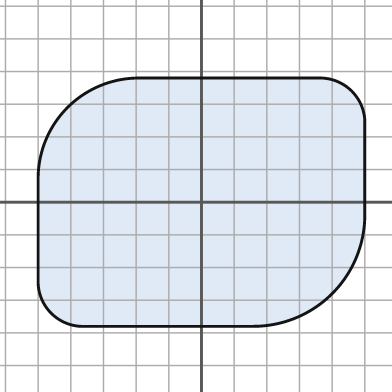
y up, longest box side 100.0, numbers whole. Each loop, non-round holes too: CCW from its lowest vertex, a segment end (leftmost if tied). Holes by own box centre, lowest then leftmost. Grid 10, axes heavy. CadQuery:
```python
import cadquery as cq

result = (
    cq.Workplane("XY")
    .moveTo(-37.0, -38.0)
    .lineTo(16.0, -38.0)
    .threePointArc((40.0, -28.0), (50.0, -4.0))
    .lineTo(50.0, 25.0)
    .threePointArc((46.0, 34.0), (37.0, 38.0))
    .lineTo(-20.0, 38.0)
    .threePointArc((-41.0, 29.0), (-50.0, 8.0))
    .lineTo(-50.0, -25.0)
    .threePointArc((-46.0, -34.0), (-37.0, -38.0))
    .close()
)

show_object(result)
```